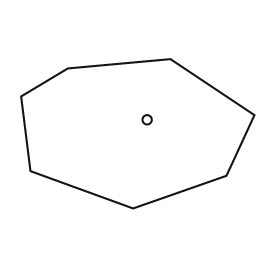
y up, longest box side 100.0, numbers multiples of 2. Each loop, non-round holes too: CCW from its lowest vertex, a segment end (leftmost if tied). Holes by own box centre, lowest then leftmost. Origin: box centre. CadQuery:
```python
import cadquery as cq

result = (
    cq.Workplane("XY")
    .moveTo(-2.0, -32.0)
    .lineTo(38.0, -18.0)
    .lineTo(50.0, 8.0)
    .lineTo(14.0, 32.0)
    .lineTo(-30.0, 28.0)
    .lineTo(-50.0, 16.0)
    .lineTo(-46.0, -16.0)
    .close()
    .moveTo(4.0, 6.0)
    .circle(2.0)
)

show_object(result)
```